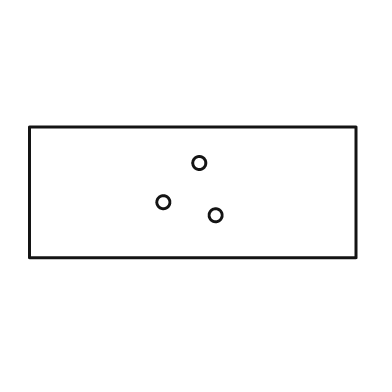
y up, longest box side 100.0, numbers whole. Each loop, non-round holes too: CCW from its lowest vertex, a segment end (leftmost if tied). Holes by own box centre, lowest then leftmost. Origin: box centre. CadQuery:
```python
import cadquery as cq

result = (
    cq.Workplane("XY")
    .moveTo(-50.0, -20.0)
    .lineTo(50.0, -20.0)
    .lineTo(50.0, 20.0)
    .lineTo(-50.0, 20.0)
    .close()
    .moveTo(7.0, -7.0)
    .circle(2.0)
    .moveTo(-9.0, -3.0)
    .circle(2.0)
    .moveTo(2.0, 9.0)
    .circle(2.0)
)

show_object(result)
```